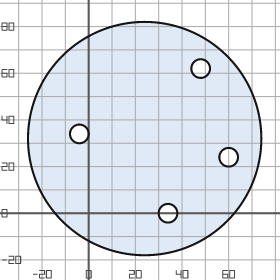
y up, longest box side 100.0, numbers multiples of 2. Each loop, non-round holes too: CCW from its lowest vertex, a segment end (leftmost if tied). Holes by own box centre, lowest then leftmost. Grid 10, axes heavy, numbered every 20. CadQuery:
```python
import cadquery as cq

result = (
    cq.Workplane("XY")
    .moveTo(24.0, 32.0)
    .circle(50.0)
    .moveTo(34.0, 0.0)
    .circle(4.0)
    .moveTo(60.0, 24.0)
    .circle(4.0)
    .moveTo(-4.0, 34.0)
    .circle(4.0)
    .moveTo(48.0, 62.0)
    .circle(4.0)
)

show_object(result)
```